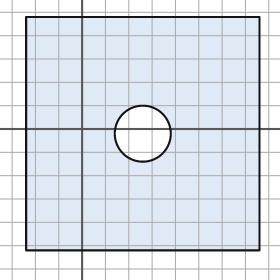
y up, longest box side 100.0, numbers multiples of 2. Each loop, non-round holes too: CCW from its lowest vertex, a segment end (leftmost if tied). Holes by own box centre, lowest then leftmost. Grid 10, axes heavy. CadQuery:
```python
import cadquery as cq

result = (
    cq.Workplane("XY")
    .moveTo(-24.0, -52.0)
    .lineTo(76.0, -52.0)
    .lineTo(76.0, 48.0)
    .lineTo(-24.0, 48.0)
    .close()
    .moveTo(26.0, -2.0)
    .circle(12.0)
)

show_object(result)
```